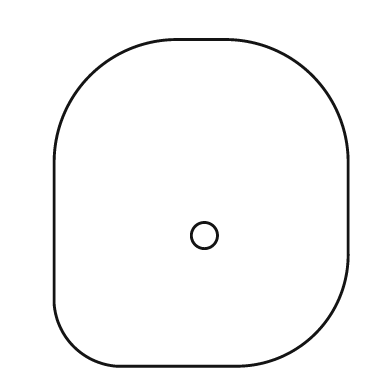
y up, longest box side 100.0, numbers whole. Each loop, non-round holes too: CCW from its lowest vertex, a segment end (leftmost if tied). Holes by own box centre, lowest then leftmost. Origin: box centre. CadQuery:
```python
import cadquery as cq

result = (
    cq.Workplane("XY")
    .moveTo(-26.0, -50.0)
    .lineTo(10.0, -50.0)
    .threePointArc((35.0, -40.0), (45.0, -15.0))
    .lineTo(45.0, 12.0)
    .threePointArc((34.0, 39.0), (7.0, 50.0))
    .lineTo(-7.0, 50.0)
    .threePointArc((-34.0, 39.0), (-45.0, 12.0))
    .lineTo(-45.0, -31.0)
    .threePointArc((-39.0, -44.0), (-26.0, -50.0))
    .close()
    .moveTo(1.0, -10.0)
    .circle(4.0)
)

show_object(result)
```